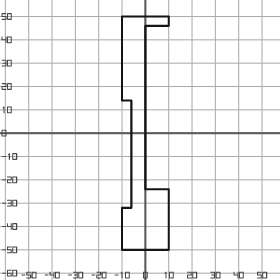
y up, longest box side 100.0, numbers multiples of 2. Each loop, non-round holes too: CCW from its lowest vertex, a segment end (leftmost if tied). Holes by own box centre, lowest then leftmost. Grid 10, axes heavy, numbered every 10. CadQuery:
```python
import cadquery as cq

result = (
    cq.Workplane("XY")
    .moveTo(-10.0, -50.0)
    .lineTo(10.0, -50.0)
    .lineTo(10.0, -24.0)
    .lineTo(0.0, -24.0)
    .lineTo(0.0, 46.0)
    .lineTo(10.0, 46.0)
    .lineTo(10.0, 50.0)
    .lineTo(-10.0, 50.0)
    .lineTo(-10.0, 14.0)
    .lineTo(-6.0, 14.0)
    .lineTo(-6.0, -32.0)
    .lineTo(-10.0, -32.0)
    .close()
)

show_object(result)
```